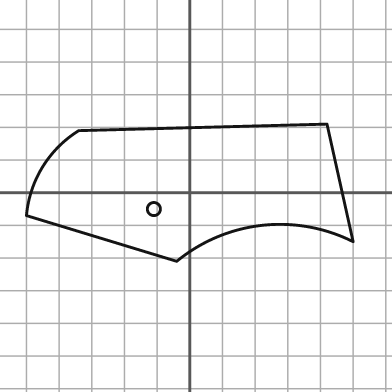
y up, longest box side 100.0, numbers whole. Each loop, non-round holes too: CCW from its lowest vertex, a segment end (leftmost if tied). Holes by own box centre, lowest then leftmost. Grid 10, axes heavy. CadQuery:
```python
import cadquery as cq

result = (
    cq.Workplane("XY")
    .moveTo(-4.0, -21.0)
    .threePointArc((22.0, -10.0), (50.0, -15.0))
    .lineTo(42.0, 21.0)
    .lineTo(-34.0, 19.0)
    .threePointArc((-45.0, 8.0), (-50.0, -7.0))
    .close()
    .moveTo(-11.0, -5.0)
    .circle(2.0)
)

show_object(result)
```